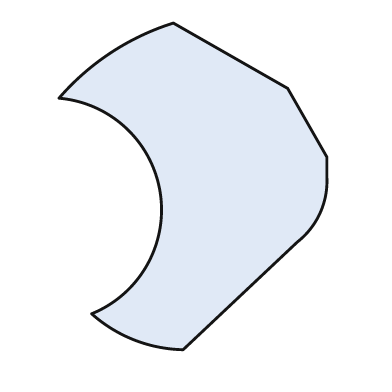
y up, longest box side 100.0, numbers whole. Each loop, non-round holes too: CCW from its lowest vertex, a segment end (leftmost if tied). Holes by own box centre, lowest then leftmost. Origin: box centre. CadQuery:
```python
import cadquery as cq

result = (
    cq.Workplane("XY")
    .moveTo(-3.0, -50.0)
    .lineTo(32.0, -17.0)
    .threePointArc((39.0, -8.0), (41.0, 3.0))
    .lineTo(41.0, 9.0)
    .lineTo(29.0, 30.0)
    .lineTo(-6.0, 50.0)
    .threePointArc((-25.0, 41.0), (-41.0, 27.0))
    .threePointArc((-10.0, -2.0), (-31.0, -39.0))
    .threePointArc((-18.0, -47.0), (-3.0, -50.0))
    .close()
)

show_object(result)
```